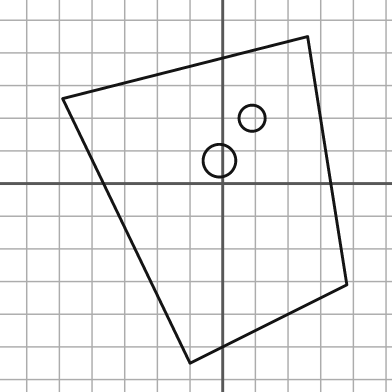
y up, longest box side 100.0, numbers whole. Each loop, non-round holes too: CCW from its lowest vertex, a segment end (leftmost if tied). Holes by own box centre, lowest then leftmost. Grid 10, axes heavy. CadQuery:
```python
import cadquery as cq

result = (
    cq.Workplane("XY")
    .moveTo(-10.0, -55.0)
    .lineTo(38.0, -31.0)
    .lineTo(26.0, 45.0)
    .lineTo(-49.0, 26.0)
    .close()
    .moveTo(-1.0, 7.0)
    .circle(5.0)
    .moveTo(9.0, 20.0)
    .circle(4.0)
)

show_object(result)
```